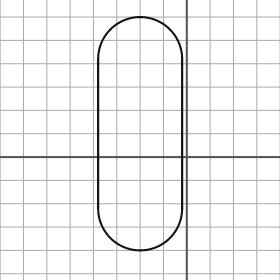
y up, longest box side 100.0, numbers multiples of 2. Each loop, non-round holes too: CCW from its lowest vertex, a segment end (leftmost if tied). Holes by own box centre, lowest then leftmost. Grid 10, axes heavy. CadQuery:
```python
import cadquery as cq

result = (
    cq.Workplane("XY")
    .moveTo(-38.0, -22.0)
    .threePointArc((-20.0, -40.0), (-2.0, -22.0))
    .lineTo(-2.0, 42.0)
    .threePointArc((-20.0, 60.0), (-38.0, 42.0))
    .close()
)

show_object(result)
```